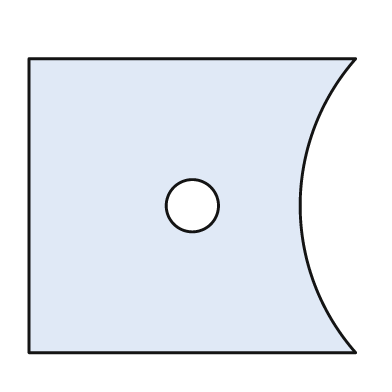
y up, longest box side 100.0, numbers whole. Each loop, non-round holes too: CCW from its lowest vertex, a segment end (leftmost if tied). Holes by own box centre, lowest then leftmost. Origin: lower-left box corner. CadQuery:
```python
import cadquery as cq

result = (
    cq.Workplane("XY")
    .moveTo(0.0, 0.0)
    .lineTo(100.0, 0.0)
    .threePointArc((83.0, 45.0), (100.0, 90.0))
    .lineTo(0.0, 90.0)
    .close()
    .moveTo(50.0, 45.0)
    .circle(8.0)
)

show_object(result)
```